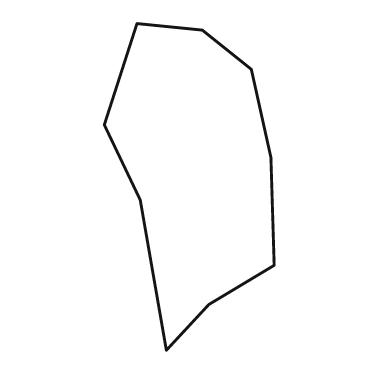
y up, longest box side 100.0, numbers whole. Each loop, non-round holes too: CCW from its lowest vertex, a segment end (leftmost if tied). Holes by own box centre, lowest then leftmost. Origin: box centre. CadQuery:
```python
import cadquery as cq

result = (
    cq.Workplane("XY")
    .moveTo(-7.0, -50.0)
    .lineTo(6.0, -36.0)
    .lineTo(26.0, -24.0)
    .lineTo(25.0, 9.0)
    .lineTo(19.0, 36.0)
    .lineTo(4.0, 48.0)
    .lineTo(-16.0, 50.0)
    .lineTo(-26.0, 19.0)
    .lineTo(-15.0, -4.0)
    .close()
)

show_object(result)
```